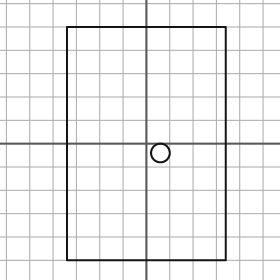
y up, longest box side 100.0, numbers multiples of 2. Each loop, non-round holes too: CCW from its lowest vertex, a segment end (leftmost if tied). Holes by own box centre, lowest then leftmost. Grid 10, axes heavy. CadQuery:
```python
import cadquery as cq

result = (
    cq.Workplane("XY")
    .moveTo(-34.0, -50.0)
    .lineTo(34.0, -50.0)
    .lineTo(34.0, 50.0)
    .lineTo(-34.0, 50.0)
    .close()
    .moveTo(6.0, -4.0)
    .circle(4.0)
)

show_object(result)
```